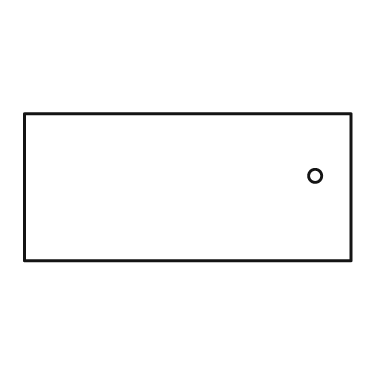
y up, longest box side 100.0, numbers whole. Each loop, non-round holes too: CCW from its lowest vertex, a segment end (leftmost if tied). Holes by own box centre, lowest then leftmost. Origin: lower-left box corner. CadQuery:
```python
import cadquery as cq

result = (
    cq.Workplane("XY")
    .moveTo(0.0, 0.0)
    .lineTo(100.0, 0.0)
    .lineTo(100.0, 45.0)
    .lineTo(0.0, 45.0)
    .close()
    .moveTo(89.0, 26.0)
    .circle(2.0)
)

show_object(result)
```